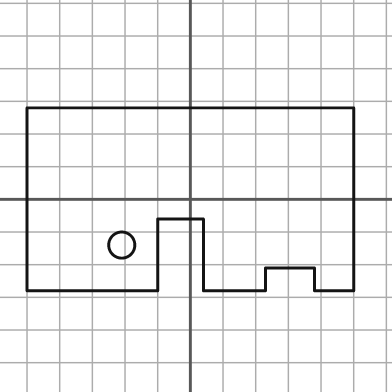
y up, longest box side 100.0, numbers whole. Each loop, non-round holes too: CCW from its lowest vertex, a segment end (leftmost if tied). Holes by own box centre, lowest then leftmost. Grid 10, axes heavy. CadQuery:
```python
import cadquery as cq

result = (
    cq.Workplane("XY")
    .moveTo(-50.0, -28.0)
    .lineTo(-10.0, -28.0)
    .lineTo(-10.0, -6.0)
    .lineTo(4.0, -6.0)
    .lineTo(4.0, -28.0)
    .lineTo(23.0, -28.0)
    .lineTo(23.0, -21.0)
    .lineTo(38.0, -21.0)
    .lineTo(38.0, -28.0)
    .lineTo(50.0, -28.0)
    .lineTo(50.0, 28.0)
    .lineTo(-50.0, 28.0)
    .close()
    .moveTo(-21.0, -14.0)
    .circle(4.0)
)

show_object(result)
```